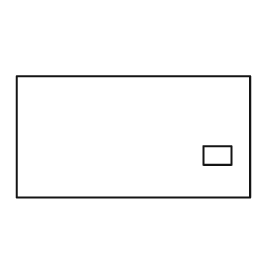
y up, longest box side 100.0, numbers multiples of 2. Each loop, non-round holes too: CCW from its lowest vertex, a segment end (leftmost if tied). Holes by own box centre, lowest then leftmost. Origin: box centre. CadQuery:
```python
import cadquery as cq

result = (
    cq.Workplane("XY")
    .moveTo(-50.0, -26.0)
    .lineTo(50.0, -26.0)
    .lineTo(50.0, 26.0)
    .lineTo(-50.0, 26.0)
    .close()
    .moveTo(30.0, -12.0)
    .lineTo(42.0, -12.0)
    .lineTo(42.0, -4.0)
    .lineTo(30.0, -4.0)
    .close()
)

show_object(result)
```